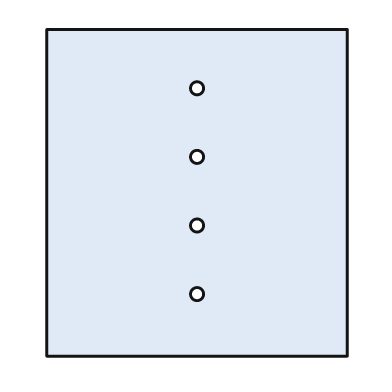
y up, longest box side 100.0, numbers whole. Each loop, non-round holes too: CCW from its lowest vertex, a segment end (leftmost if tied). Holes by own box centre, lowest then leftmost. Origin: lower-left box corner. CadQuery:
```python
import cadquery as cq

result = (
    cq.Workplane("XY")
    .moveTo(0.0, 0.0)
    .lineTo(92.0, 0.0)
    .lineTo(92.0, 100.0)
    .lineTo(0.0, 100.0)
    .close()
    .moveTo(46.0, 19.0)
    .circle(2.0)
    .moveTo(46.0, 40.0)
    .circle(2.0)
    .moveTo(46.0, 61.0)
    .circle(2.0)
    .moveTo(46.0, 82.0)
    .circle(2.0)
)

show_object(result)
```